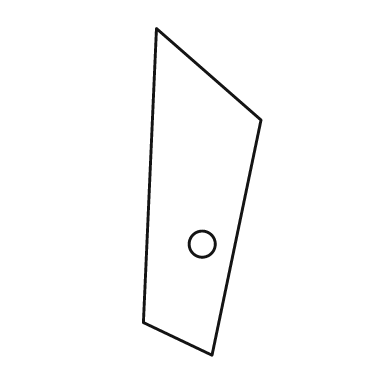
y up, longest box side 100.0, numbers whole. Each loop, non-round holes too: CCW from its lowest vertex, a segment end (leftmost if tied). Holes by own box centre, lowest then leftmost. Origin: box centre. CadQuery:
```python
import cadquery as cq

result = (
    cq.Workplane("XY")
    .moveTo(3.0, -50.0)
    .lineTo(18.0, 22.0)
    .lineTo(-14.0, 50.0)
    .lineTo(-18.0, -40.0)
    .close()
    .moveTo(0.0, -16.0)
    .circle(4.0)
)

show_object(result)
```